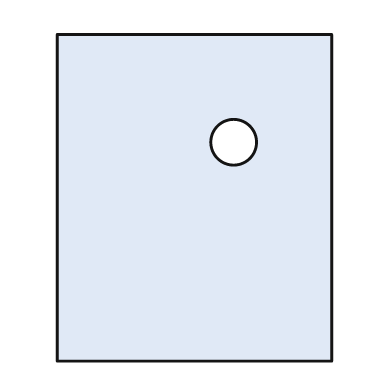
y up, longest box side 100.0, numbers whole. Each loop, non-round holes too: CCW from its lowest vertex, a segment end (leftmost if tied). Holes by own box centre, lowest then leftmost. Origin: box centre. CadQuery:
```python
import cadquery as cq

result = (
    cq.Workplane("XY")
    .moveTo(-42.0, -50.0)
    .lineTo(42.0, -50.0)
    .lineTo(42.0, 50.0)
    .lineTo(-42.0, 50.0)
    .close()
    .moveTo(12.0, 17.0)
    .circle(7.0)
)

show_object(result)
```